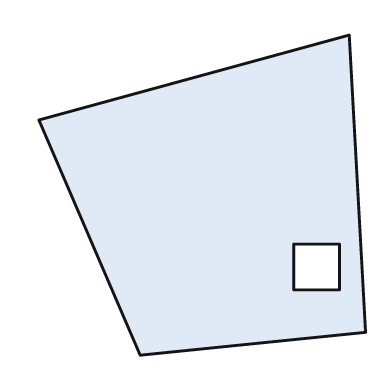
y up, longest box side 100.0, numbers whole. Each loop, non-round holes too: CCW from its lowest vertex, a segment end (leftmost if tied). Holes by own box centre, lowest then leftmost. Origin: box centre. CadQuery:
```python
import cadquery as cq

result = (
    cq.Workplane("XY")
    .moveTo(-19.0, -49.0)
    .lineTo(50.0, -42.0)
    .lineTo(45.0, 49.0)
    .lineTo(-50.0, 23.0)
    .close()
    .moveTo(28.0, -29.0)
    .lineTo(42.0, -29.0)
    .lineTo(42.0, -15.0)
    .lineTo(28.0, -15.0)
    .close()
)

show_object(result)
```